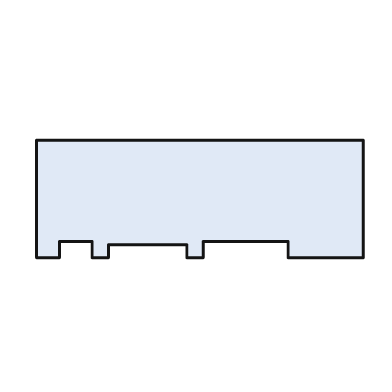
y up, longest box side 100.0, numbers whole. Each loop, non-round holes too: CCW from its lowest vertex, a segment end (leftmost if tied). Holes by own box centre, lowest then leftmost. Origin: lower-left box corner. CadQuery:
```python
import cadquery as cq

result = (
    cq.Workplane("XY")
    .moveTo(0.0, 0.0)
    .lineTo(7.0, 0.0)
    .lineTo(7.0, 5.0)
    .lineTo(17.0, 5.0)
    .lineTo(17.0, 0.0)
    .lineTo(22.0, 0.0)
    .lineTo(22.0, 4.0)
    .lineTo(46.0, 4.0)
    .lineTo(46.0, 0.0)
    .lineTo(51.0, 0.0)
    .lineTo(51.0, 5.0)
    .lineTo(77.0, 5.0)
    .lineTo(77.0, 0.0)
    .lineTo(100.0, 0.0)
    .lineTo(100.0, 36.0)
    .lineTo(0.0, 36.0)
    .close()
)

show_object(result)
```